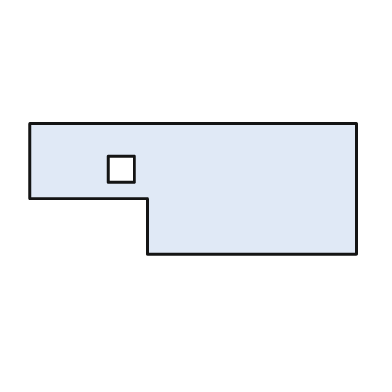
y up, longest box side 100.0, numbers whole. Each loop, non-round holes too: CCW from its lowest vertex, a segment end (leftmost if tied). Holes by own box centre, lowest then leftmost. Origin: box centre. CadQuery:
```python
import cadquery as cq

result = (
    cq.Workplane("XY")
    .moveTo(-14.0, -20.0)
    .lineTo(50.0, -20.0)
    .lineTo(50.0, 20.0)
    .lineTo(-50.0, 20.0)
    .lineTo(-50.0, -3.0)
    .lineTo(-14.0, -3.0)
    .close()
    .moveTo(-26.0, 2.0)
    .lineTo(-18.0, 2.0)
    .lineTo(-18.0, 10.0)
    .lineTo(-26.0, 10.0)
    .close()
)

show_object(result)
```